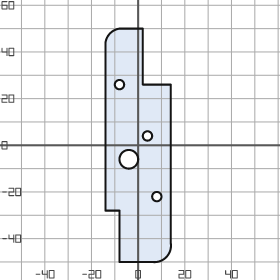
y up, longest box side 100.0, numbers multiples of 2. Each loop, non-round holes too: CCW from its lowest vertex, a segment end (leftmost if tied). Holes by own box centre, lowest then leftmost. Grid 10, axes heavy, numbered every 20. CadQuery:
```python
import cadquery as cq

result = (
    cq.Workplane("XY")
    .moveTo(-8.0, -50.0)
    .lineTo(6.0, -50.0)
    .threePointArc((12.0, -48.0), (14.0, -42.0))
    .lineTo(14.0, 26.0)
    .lineTo(2.0, 26.0)
    .lineTo(2.0, 50.0)
    .lineTo(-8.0, 50.0)
    .threePointArc((-12.0, 48.0), (-14.0, 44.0))
    .lineTo(-14.0, -28.0)
    .lineTo(-8.0, -28.0)
    .close()
    .moveTo(8.0, -22.0)
    .circle(2.0)
    .moveTo(-4.0, -6.0)
    .circle(4.0)
    .moveTo(4.0, 4.0)
    .circle(2.0)
    .moveTo(-8.0, 26.0)
    .circle(2.0)
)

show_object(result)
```